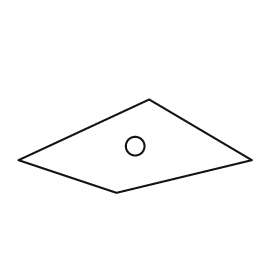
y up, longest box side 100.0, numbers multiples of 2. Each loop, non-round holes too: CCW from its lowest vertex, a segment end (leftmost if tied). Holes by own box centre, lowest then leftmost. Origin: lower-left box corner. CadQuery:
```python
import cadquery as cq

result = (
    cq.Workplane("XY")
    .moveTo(42.0, 0.0)
    .lineTo(100.0, 14.0)
    .lineTo(56.0, 40.0)
    .lineTo(0.0, 14.0)
    .close()
    .moveTo(50.0, 20.0)
    .circle(4.0)
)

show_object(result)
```